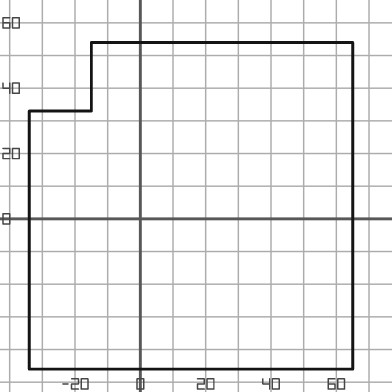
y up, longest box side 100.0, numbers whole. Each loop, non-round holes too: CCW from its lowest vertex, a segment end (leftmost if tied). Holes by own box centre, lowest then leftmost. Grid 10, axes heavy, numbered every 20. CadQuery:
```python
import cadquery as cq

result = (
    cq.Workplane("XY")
    .moveTo(-34.0, -46.0)
    .lineTo(65.0, -46.0)
    .lineTo(65.0, 54.0)
    .lineTo(-15.0, 54.0)
    .lineTo(-15.0, 33.0)
    .lineTo(-34.0, 33.0)
    .close()
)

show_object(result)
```